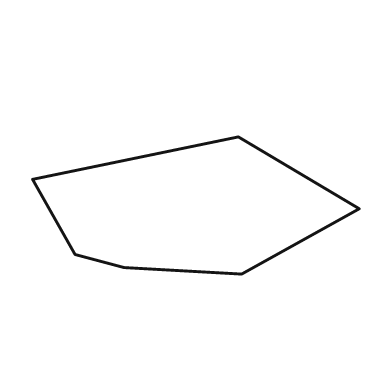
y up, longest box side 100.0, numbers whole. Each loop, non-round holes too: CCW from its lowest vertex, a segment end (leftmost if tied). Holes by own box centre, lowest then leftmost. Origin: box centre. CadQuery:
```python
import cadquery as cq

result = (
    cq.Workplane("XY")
    .moveTo(14.0, -21.0)
    .lineTo(50.0, -1.0)
    .lineTo(13.0, 21.0)
    .lineTo(-50.0, 8.0)
    .lineTo(-37.0, -15.0)
    .lineTo(-22.0, -19.0)
    .close()
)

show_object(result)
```